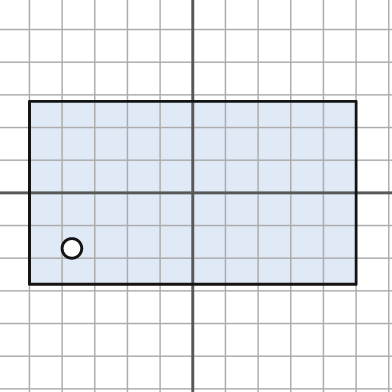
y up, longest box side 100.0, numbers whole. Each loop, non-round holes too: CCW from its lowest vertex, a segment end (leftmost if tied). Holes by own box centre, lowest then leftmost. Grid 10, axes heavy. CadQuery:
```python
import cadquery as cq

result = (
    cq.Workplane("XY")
    .moveTo(-50.0, -28.0)
    .lineTo(50.0, -28.0)
    .lineTo(50.0, 28.0)
    .lineTo(-50.0, 28.0)
    .close()
    .moveTo(-37.0, -17.0)
    .circle(3.0)
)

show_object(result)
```